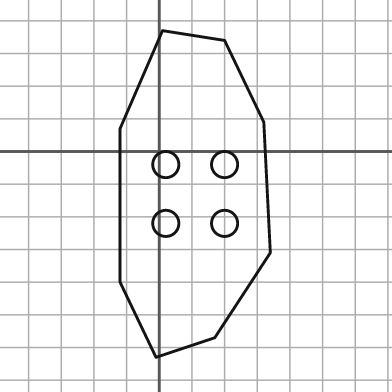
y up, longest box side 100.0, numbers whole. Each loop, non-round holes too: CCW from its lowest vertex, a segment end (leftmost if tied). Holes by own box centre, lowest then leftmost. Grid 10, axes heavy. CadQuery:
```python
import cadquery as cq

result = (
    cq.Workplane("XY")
    .moveTo(-1.0, -63.0)
    .lineTo(17.0, -57.0)
    .lineTo(34.0, -31.0)
    .lineTo(32.0, 9.0)
    .lineTo(20.0, 34.0)
    .lineTo(1.0, 37.0)
    .lineTo(-12.0, 7.0)
    .lineTo(-12.0, -40.0)
    .close()
    .moveTo(2.0, -22.0)
    .circle(4.0)
    .moveTo(20.0, -22.0)
    .circle(4.0)
    .moveTo(2.0, -4.0)
    .circle(4.0)
    .moveTo(20.0, -4.0)
    .circle(4.0)
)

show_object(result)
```